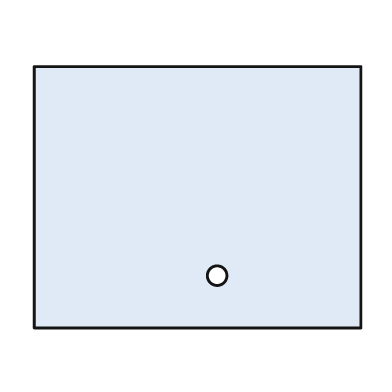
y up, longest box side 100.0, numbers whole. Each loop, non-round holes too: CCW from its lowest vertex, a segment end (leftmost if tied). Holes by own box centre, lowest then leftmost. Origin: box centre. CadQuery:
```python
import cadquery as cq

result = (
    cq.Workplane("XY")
    .moveTo(-50.0, -40.0)
    .lineTo(50.0, -40.0)
    .lineTo(50.0, 40.0)
    .lineTo(-50.0, 40.0)
    .close()
    .moveTo(6.0, -24.0)
    .circle(3.0)
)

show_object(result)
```